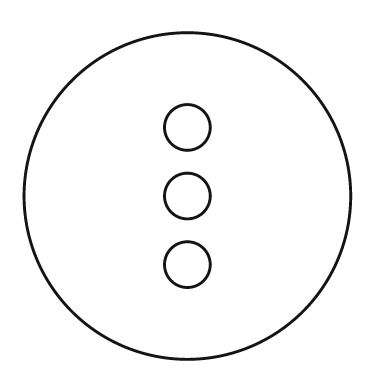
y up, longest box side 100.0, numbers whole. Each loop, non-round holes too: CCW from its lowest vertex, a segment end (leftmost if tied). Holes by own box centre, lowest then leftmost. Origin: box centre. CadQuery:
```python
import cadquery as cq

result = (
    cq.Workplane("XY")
    .moveTo(0.0, 0.0)
    .circle(50.0)
    .moveTo(0.0, -21.0)
    .circle(7.0)
    .moveTo(0.0, 0.0)
    .circle(7.0)
    .moveTo(0.0, 21.0)
    .circle(7.0)
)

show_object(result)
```